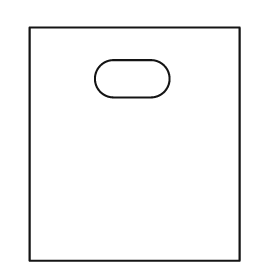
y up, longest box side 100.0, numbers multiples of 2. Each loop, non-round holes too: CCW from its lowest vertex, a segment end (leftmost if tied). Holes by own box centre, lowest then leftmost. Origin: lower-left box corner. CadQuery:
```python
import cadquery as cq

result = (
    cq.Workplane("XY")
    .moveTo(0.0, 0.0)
    .lineTo(90.0, 0.0)
    .lineTo(90.0, 100.0)
    .lineTo(0.0, 100.0)
    .close()
    .moveTo(36.0, 70.0)
    .lineTo(52.0, 70.0)
    .threePointArc((60.0, 78.0), (52.0, 86.0))
    .lineTo(36.0, 86.0)
    .threePointArc((28.0, 78.0), (36.0, 70.0))
    .close()
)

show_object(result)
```